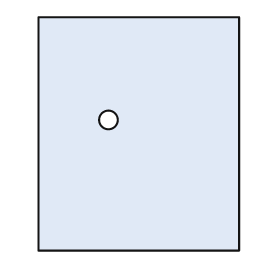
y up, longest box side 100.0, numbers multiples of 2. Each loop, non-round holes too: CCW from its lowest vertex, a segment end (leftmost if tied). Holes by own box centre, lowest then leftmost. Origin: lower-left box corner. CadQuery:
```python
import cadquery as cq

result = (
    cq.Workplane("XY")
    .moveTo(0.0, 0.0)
    .lineTo(86.0, 0.0)
    .lineTo(86.0, 100.0)
    .lineTo(0.0, 100.0)
    .close()
    .moveTo(30.0, 56.0)
    .circle(4.0)
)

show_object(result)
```